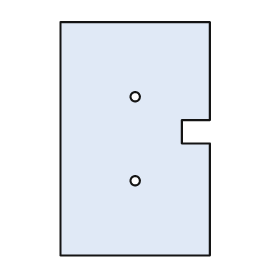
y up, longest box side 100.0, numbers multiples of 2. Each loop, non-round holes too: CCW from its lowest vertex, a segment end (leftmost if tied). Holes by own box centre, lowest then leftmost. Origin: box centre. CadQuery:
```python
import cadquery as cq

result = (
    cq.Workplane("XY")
    .moveTo(-32.0, -50.0)
    .lineTo(32.0, -50.0)
    .lineTo(32.0, -2.0)
    .lineTo(20.0, -2.0)
    .lineTo(20.0, 8.0)
    .lineTo(32.0, 8.0)
    .lineTo(32.0, 50.0)
    .lineTo(-32.0, 50.0)
    .close()
    .moveTo(0.0, -18.0)
    .circle(2.0)
    .moveTo(0.0, 18.0)
    .circle(2.0)
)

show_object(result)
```